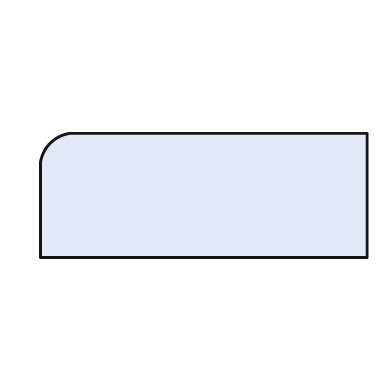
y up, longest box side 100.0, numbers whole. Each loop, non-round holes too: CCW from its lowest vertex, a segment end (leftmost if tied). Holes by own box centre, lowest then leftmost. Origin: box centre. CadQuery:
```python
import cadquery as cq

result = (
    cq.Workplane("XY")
    .moveTo(-50.0, -19.0)
    .lineTo(50.0, -19.0)
    .lineTo(50.0, 19.0)
    .lineTo(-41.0, 19.0)
    .threePointArc((-47.0, 16.0), (-50.0, 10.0))
    .close()
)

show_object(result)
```